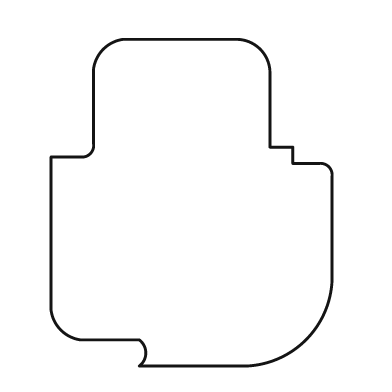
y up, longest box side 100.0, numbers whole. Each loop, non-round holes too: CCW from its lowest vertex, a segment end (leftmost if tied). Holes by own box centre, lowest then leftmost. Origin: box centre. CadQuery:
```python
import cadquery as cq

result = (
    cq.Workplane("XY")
    .moveTo(-16.0, -50.0)
    .lineTo(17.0, -50.0)
    .threePointArc((35.0, -42.0), (43.0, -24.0))
    .lineTo(43.0, 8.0)
    .threePointArc((42.0, 11.0), (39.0, 12.0))
    .lineTo(31.0, 12.0)
    .lineTo(31.0, 17.0)
    .lineTo(24.0, 17.0)
    .lineTo(24.0, 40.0)
    .threePointArc((21.0, 47.0), (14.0, 50.0))
    .lineTo(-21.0, 50.0)
    .threePointArc((-27.0, 47.0), (-30.0, 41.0))
    .lineTo(-30.0, 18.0)
    .threePointArc((-31.0, 15.0), (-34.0, 14.0))
    .lineTo(-43.0, 14.0)
    .lineTo(-43.0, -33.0)
    .threePointArc((-40.0, -39.0), (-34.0, -42.0))
    .lineTo(-16.0, -42.0)
    .threePointArc((-14.0, -46.0), (-16.0, -50.0))
    .close()
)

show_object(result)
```